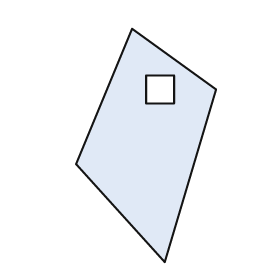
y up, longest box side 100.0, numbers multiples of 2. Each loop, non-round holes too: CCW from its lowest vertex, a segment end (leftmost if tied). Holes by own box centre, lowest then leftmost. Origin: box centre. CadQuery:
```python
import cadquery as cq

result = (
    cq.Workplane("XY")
    .moveTo(8.0, -50.0)
    .lineTo(30.0, 24.0)
    .lineTo(-6.0, 50.0)
    .lineTo(-30.0, -8.0)
    .close()
    .moveTo(0.0, 18.0)
    .lineTo(12.0, 18.0)
    .lineTo(12.0, 30.0)
    .lineTo(0.0, 30.0)
    .close()
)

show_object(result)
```